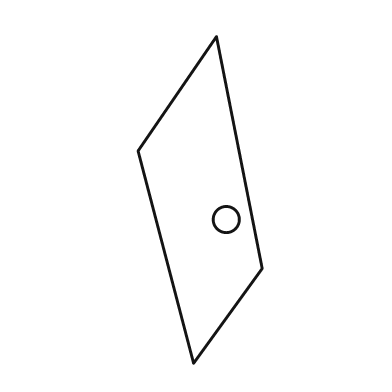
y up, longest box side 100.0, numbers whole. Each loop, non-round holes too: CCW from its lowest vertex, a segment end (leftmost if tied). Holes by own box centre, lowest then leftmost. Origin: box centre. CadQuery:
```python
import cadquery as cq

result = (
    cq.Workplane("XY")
    .moveTo(-2.0, -50.0)
    .lineTo(19.0, -21.0)
    .lineTo(5.0, 50.0)
    .lineTo(-19.0, 15.0)
    .close()
    .moveTo(8.0, -6.0)
    .circle(4.0)
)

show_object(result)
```